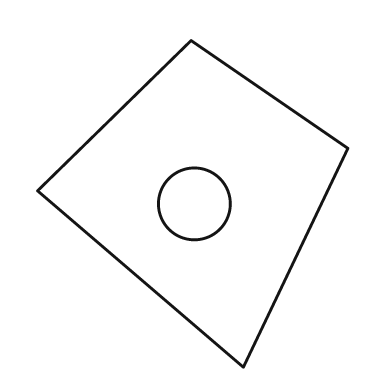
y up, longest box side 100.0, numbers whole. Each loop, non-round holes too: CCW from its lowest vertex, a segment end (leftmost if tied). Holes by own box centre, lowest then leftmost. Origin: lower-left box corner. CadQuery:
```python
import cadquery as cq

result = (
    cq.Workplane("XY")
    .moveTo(63.0, 0.0)
    .lineTo(95.0, 67.0)
    .lineTo(47.0, 100.0)
    .lineTo(0.0, 54.0)
    .close()
    .moveTo(48.0, 50.0)
    .circle(11.0)
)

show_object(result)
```